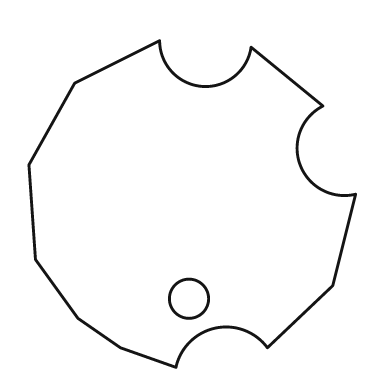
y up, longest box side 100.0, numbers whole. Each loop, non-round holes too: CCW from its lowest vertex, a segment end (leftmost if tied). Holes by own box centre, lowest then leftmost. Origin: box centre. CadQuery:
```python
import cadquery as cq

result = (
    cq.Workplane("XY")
    .moveTo(-5.0, -50.0)
    .threePointArc((7.0, -38.0), (23.0, -44.0))
    .lineTo(43.0, -25.0)
    .lineTo(50.0, 3.0)
    .threePointArc((33.0, 12.0), (40.0, 30.0))
    .lineTo(18.0, 48.0)
    .threePointArc((3.0, 36.0), (-10.0, 50.0))
    .lineTo(-36.0, 37.0)
    .lineTo(-50.0, 12.0)
    .lineTo(-48.0, -17.0)
    .lineTo(-35.0, -35.0)
    .lineTo(-22.0, -44.0)
    .close()
    .moveTo(-1.0, -29.0)
    .circle(6.0)
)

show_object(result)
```